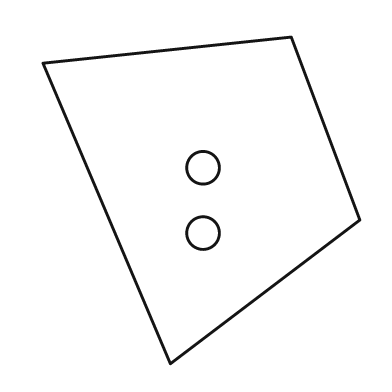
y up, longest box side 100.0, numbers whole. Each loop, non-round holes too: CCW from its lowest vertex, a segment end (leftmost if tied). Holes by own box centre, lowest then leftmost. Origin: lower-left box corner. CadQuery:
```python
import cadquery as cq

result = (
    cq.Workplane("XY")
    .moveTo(39.0, 0.0)
    .lineTo(97.0, 44.0)
    .lineTo(76.0, 100.0)
    .lineTo(0.0, 92.0)
    .close()
    .moveTo(49.0, 40.0)
    .circle(5.0)
    .moveTo(49.0, 60.0)
    .circle(5.0)
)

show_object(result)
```